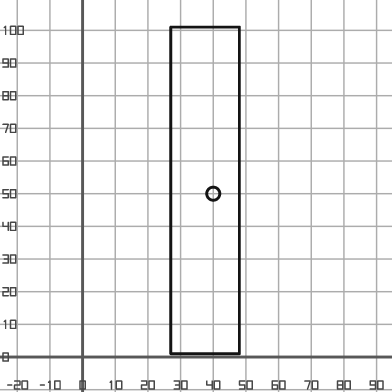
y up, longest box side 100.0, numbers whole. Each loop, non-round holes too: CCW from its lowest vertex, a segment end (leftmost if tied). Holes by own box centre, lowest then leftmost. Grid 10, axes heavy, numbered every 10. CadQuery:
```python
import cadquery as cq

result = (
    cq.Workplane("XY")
    .moveTo(27.0, 1.0)
    .lineTo(48.0, 1.0)
    .lineTo(48.0, 101.0)
    .lineTo(27.0, 101.0)
    .close()
    .moveTo(40.0, 50.0)
    .circle(2.0)
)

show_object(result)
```